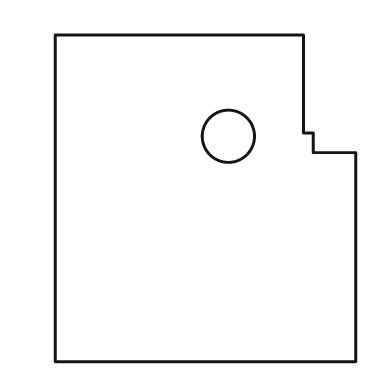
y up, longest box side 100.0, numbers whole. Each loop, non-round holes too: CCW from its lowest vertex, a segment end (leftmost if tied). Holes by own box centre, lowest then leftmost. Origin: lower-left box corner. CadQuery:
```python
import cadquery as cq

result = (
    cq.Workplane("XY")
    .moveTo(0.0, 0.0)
    .lineTo(92.0, 0.0)
    .lineTo(92.0, 64.0)
    .lineTo(79.0, 64.0)
    .lineTo(79.0, 70.0)
    .lineTo(76.0, 70.0)
    .lineTo(76.0, 100.0)
    .lineTo(0.0, 100.0)
    .close()
    .moveTo(53.0, 69.0)
    .circle(8.0)
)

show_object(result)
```